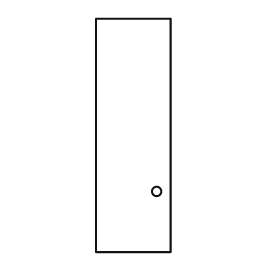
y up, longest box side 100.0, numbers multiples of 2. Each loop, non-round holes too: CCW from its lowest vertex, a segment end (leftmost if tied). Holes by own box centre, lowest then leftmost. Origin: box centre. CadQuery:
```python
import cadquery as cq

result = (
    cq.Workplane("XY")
    .moveTo(-16.0, -50.0)
    .lineTo(16.0, -50.0)
    .lineTo(16.0, 50.0)
    .lineTo(-16.0, 50.0)
    .close()
    .moveTo(10.0, -24.0)
    .circle(2.0)
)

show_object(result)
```